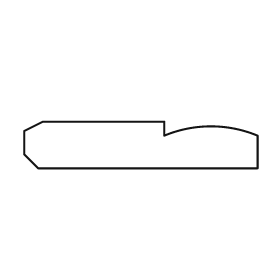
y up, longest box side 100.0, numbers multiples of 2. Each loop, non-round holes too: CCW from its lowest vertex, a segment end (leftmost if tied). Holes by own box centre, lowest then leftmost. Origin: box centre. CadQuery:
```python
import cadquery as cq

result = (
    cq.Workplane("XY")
    .moveTo(-44.0, -10.0)
    .lineTo(50.0, -10.0)
    .lineTo(50.0, 4.0)
    .threePointArc((30.0, 8.0), (10.0, 4.0))
    .lineTo(10.0, 10.0)
    .lineTo(-42.0, 10.0)
    .lineTo(-50.0, 6.0)
    .lineTo(-50.0, -4.0)
    .close()
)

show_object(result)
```